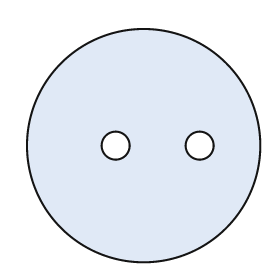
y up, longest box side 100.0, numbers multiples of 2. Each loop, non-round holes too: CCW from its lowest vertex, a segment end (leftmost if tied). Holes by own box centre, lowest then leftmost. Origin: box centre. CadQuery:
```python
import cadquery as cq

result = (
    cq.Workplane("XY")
    .moveTo(0.0, 0.0)
    .circle(50.0)
    .moveTo(-12.0, 0.0)
    .circle(6.0)
    .moveTo(24.0, 0.0)
    .circle(6.0)
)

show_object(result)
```